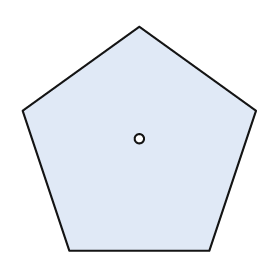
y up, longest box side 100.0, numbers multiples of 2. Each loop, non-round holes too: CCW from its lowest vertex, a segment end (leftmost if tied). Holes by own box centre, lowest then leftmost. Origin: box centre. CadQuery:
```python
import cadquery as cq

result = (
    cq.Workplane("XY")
    .moveTo(-30.0, -48.0)
    .lineTo(30.0, -48.0)
    .lineTo(50.0, 12.0)
    .lineTo(0.0, 48.0)
    .lineTo(-50.0, 12.0)
    .close()
    .moveTo(0.0, 0.0)
    .circle(2.0)
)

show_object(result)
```